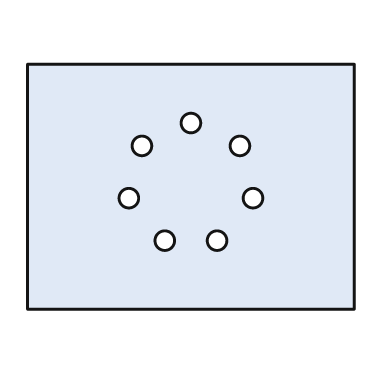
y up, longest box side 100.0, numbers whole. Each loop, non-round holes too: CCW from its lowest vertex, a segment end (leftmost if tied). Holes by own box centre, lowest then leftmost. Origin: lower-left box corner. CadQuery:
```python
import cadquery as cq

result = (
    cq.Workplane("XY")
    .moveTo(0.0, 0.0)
    .lineTo(100.0, 0.0)
    .lineTo(100.0, 75.0)
    .lineTo(0.0, 75.0)
    .close()
    .moveTo(42.0, 21.0)
    .circle(3.0)
    .moveTo(58.0, 21.0)
    .circle(3.0)
    .moveTo(31.0, 34.0)
    .circle(3.0)
    .moveTo(69.0, 34.0)
    .circle(3.0)
    .moveTo(35.0, 50.0)
    .circle(3.0)
    .moveTo(65.0, 50.0)
    .circle(3.0)
    .moveTo(50.0, 57.0)
    .circle(3.0)
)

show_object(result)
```